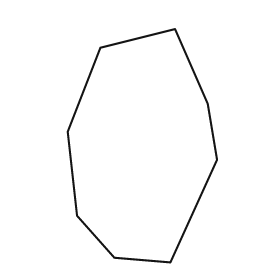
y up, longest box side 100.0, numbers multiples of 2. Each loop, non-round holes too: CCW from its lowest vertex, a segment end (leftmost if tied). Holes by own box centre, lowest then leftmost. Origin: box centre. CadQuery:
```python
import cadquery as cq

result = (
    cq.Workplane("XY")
    .moveTo(12.0, -50.0)
    .lineTo(32.0, -6.0)
    .lineTo(28.0, 18.0)
    .lineTo(14.0, 50.0)
    .lineTo(-18.0, 42.0)
    .lineTo(-32.0, 6.0)
    .lineTo(-28.0, -30.0)
    .lineTo(-12.0, -48.0)
    .close()
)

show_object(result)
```